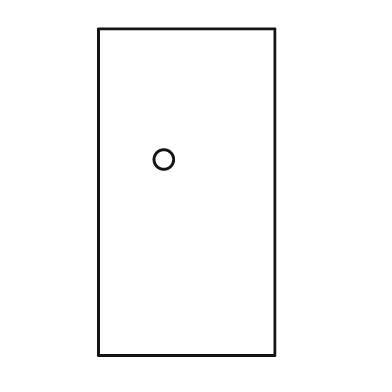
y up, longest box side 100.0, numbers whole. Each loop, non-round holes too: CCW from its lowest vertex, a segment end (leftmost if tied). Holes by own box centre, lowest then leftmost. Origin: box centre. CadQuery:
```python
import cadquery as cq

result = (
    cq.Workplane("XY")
    .moveTo(-27.0, -50.0)
    .lineTo(27.0, -50.0)
    .lineTo(27.0, 50.0)
    .lineTo(-27.0, 50.0)
    .close()
    .moveTo(-7.0, 10.0)
    .circle(3.0)
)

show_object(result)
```